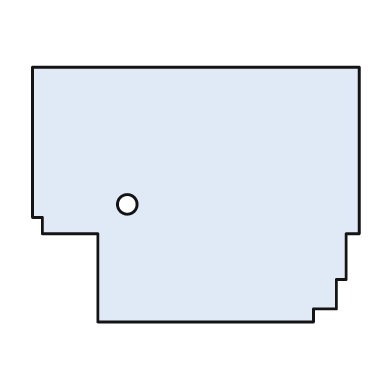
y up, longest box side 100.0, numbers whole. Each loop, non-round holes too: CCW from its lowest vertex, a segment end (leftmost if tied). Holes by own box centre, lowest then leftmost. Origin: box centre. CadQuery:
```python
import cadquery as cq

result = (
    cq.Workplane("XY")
    .moveTo(-30.0, -39.0)
    .lineTo(36.0, -39.0)
    .lineTo(36.0, -35.0)
    .lineTo(43.0, -35.0)
    .lineTo(43.0, -26.0)
    .lineTo(46.0, -26.0)
    .lineTo(46.0, -12.0)
    .lineTo(50.0, -12.0)
    .lineTo(50.0, 39.0)
    .lineTo(-50.0, 39.0)
    .lineTo(-50.0, -7.0)
    .lineTo(-47.0, -7.0)
    .lineTo(-47.0, -12.0)
    .lineTo(-30.0, -12.0)
    .close()
    .moveTo(-21.0, -3.0)
    .circle(3.0)
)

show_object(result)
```